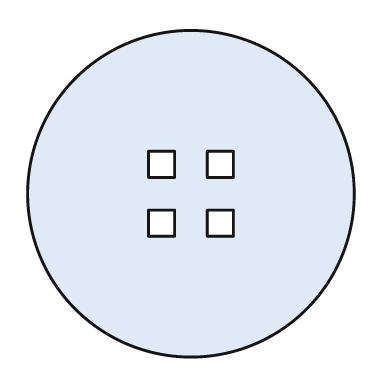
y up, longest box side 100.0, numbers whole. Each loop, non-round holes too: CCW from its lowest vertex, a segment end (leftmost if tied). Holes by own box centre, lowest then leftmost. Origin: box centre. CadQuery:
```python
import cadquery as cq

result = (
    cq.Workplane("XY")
    .moveTo(0.0, 0.0)
    .circle(50.0)
    .moveTo(-13.0, -13.0)
    .lineTo(-5.0, -13.0)
    .lineTo(-5.0, -5.0)
    .lineTo(-13.0, -5.0)
    .close()
    .moveTo(5.0, -13.0)
    .lineTo(13.0, -13.0)
    .lineTo(13.0, -5.0)
    .lineTo(5.0, -5.0)
    .close()
    .moveTo(-13.0, 5.0)
    .lineTo(-5.0, 5.0)
    .lineTo(-5.0, 13.0)
    .lineTo(-13.0, 13.0)
    .close()
    .moveTo(5.0, 5.0)
    .lineTo(13.0, 5.0)
    .lineTo(13.0, 13.0)
    .lineTo(5.0, 13.0)
    .close()
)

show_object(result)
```